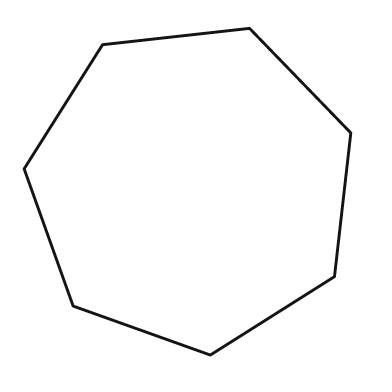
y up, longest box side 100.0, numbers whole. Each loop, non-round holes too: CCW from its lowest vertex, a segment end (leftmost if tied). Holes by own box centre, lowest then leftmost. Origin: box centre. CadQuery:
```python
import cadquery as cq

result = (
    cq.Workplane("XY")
    .moveTo(7.0, -50.0)
    .lineTo(45.0, -26.0)
    .lineTo(50.0, 18.0)
    .lineTo(19.0, 50.0)
    .lineTo(-26.0, 45.0)
    .lineTo(-50.0, 7.0)
    .lineTo(-35.0, -35.0)
    .close()
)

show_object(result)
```